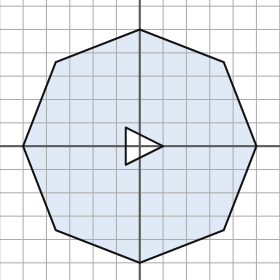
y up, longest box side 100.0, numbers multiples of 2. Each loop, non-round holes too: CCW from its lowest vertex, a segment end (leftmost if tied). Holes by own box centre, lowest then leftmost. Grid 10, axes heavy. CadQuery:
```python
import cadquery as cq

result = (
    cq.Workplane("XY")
    .moveTo(0.0, -50.0)
    .lineTo(36.0, -36.0)
    .lineTo(50.0, 0.0)
    .lineTo(36.0, 36.0)
    .lineTo(0.0, 50.0)
    .lineTo(-36.0, 36.0)
    .lineTo(-50.0, 0.0)
    .lineTo(-36.0, -36.0)
    .close()
    .moveTo(-6.0, -8.0)
    .lineTo(10.0, 0.0)
    .lineTo(-6.0, 8.0)
    .close()
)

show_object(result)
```